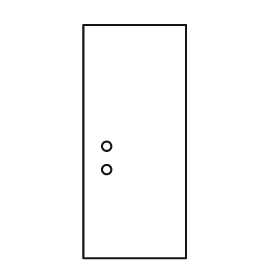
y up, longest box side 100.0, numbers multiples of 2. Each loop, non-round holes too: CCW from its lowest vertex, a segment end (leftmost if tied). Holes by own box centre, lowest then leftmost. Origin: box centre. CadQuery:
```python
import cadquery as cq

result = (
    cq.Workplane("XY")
    .moveTo(-22.0, -50.0)
    .lineTo(22.0, -50.0)
    .lineTo(22.0, 50.0)
    .lineTo(-22.0, 50.0)
    .close()
    .moveTo(-12.0, -12.0)
    .circle(2.0)
    .moveTo(-12.0, -2.0)
    .circle(2.0)
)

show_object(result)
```